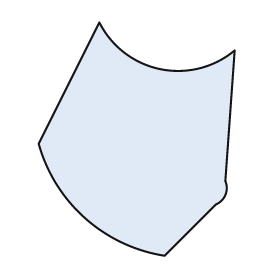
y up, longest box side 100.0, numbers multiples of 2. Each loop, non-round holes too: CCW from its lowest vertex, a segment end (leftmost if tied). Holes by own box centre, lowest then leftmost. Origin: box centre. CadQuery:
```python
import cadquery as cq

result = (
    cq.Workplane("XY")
    .moveTo(12.0, -50.0)
    .lineTo(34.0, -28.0)
    .threePointArc((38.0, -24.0), (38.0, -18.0))
    .lineTo(42.0, 38.0)
    .threePointArc((10.0, 30.0), (-16.0, 50.0))
    .lineTo(-42.0, -2.0)
    .threePointArc((-22.0, -34.0), (12.0, -50.0))
    .close()
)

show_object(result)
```